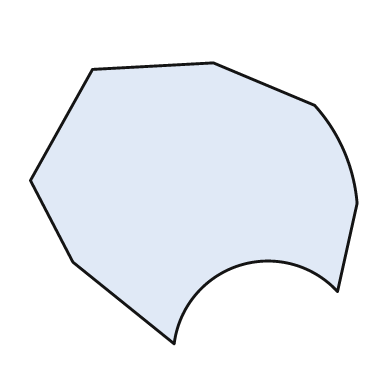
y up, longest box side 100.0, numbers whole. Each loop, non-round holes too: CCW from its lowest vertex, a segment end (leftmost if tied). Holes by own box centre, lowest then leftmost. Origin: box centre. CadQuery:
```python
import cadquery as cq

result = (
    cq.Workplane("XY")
    .moveTo(-6.0, -43.0)
    .threePointArc((14.0, -19.0), (44.0, -27.0))
    .lineTo(50.0, 0.0)
    .threePointArc((46.0, 16.0), (37.0, 30.0))
    .lineTo(6.0, 43.0)
    .lineTo(-31.0, 41.0)
    .lineTo(-50.0, 7.0)
    .lineTo(-37.0, -18.0)
    .close()
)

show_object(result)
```